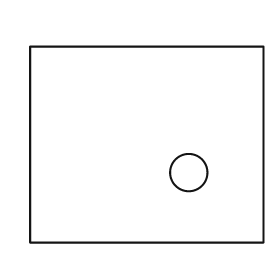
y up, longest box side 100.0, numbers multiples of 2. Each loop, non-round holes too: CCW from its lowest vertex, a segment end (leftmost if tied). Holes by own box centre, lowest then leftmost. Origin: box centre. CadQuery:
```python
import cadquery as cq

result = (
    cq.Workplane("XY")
    .moveTo(-50.0, -42.0)
    .lineTo(50.0, -42.0)
    .lineTo(50.0, 42.0)
    .lineTo(-50.0, 42.0)
    .close()
    .moveTo(18.0, -12.0)
    .circle(8.0)
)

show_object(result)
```